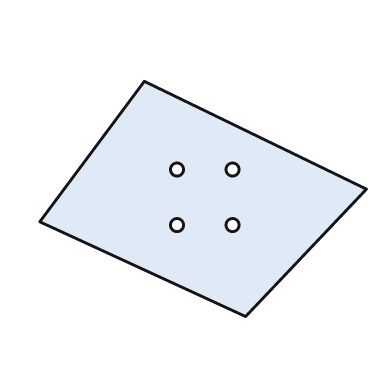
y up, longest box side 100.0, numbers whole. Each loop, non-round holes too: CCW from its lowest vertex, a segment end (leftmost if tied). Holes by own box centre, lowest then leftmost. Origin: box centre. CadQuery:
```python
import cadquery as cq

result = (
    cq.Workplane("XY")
    .moveTo(13.0, -36.0)
    .lineTo(50.0, 3.0)
    .lineTo(-18.0, 36.0)
    .lineTo(-50.0, -7.0)
    .close()
    .moveTo(-8.0, -8.0)
    .circle(2.0)
    .moveTo(9.0, -8.0)
    .circle(2.0)
    .moveTo(-8.0, 9.0)
    .circle(2.0)
    .moveTo(9.0, 9.0)
    .circle(2.0)
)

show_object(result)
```